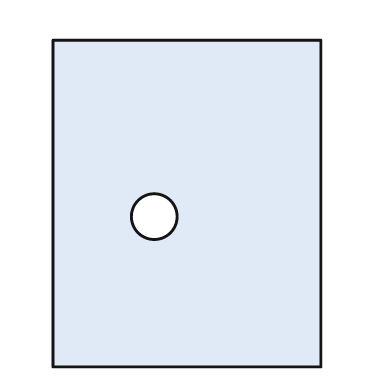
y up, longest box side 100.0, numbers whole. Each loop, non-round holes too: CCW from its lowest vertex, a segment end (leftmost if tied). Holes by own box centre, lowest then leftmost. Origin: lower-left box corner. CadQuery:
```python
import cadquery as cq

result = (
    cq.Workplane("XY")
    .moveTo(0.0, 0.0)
    .lineTo(82.0, 0.0)
    .lineTo(82.0, 100.0)
    .lineTo(0.0, 100.0)
    .close()
    .moveTo(31.0, 46.0)
    .circle(7.0)
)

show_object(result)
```